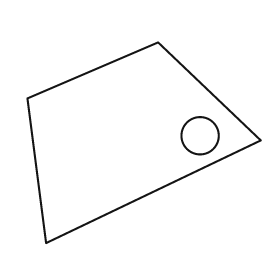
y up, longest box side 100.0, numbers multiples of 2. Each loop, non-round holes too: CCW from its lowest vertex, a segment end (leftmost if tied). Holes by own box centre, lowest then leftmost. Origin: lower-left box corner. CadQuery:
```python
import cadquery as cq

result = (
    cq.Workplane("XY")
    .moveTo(8.0, 0.0)
    .lineTo(100.0, 44.0)
    .lineTo(56.0, 86.0)
    .lineTo(0.0, 62.0)
    .close()
    .moveTo(74.0, 46.0)
    .circle(8.0)
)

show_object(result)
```